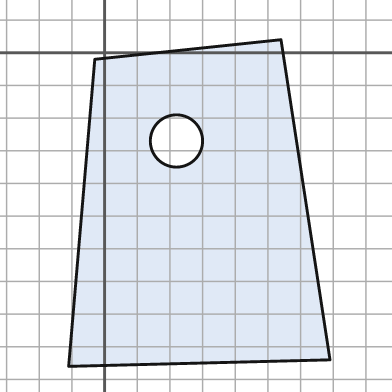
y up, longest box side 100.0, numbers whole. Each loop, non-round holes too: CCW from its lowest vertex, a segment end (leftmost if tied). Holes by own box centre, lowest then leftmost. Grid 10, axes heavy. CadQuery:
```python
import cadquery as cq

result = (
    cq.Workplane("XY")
    .moveTo(-11.0, -96.0)
    .lineTo(69.0, -94.0)
    .lineTo(54.0, 4.0)
    .lineTo(-3.0, -2.0)
    .close()
    .moveTo(22.0, -27.0)
    .circle(8.0)
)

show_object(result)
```